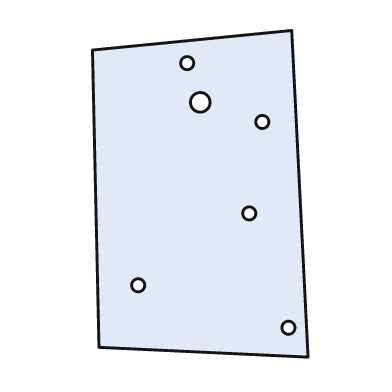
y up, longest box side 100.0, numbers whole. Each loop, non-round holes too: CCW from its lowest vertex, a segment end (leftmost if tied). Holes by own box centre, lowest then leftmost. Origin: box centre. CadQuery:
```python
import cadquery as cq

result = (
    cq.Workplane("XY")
    .moveTo(33.0, -50.0)
    .lineTo(28.0, 50.0)
    .lineTo(-33.0, 44.0)
    .lineTo(-31.0, -47.0)
    .close()
    .moveTo(27.0, -41.0)
    .circle(2.0)
    .moveTo(-19.0, -28.0)
    .circle(2.0)
    .moveTo(15.0, -6.0)
    .circle(2.0)
    .moveTo(19.0, 22.0)
    .circle(2.0)
    .moveTo(0.0, 28.0)
    .circle(3.0)
    .moveTo(-4.0, 40.0)
    .circle(2.0)
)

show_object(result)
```